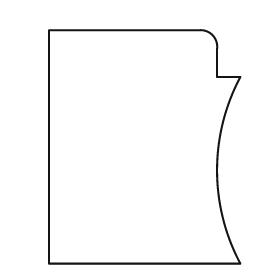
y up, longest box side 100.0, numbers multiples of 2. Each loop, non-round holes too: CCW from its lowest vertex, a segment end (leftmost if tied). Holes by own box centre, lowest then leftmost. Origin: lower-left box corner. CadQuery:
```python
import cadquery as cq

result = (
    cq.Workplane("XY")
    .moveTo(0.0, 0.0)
    .lineTo(82.0, 0.0)
    .threePointArc((72.0, 40.0), (82.0, 80.0))
    .lineTo(72.0, 80.0)
    .lineTo(72.0, 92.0)
    .threePointArc((70.0, 98.0), (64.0, 100.0))
    .lineTo(0.0, 100.0)
    .close()
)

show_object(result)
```